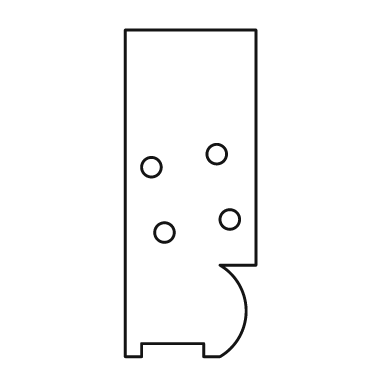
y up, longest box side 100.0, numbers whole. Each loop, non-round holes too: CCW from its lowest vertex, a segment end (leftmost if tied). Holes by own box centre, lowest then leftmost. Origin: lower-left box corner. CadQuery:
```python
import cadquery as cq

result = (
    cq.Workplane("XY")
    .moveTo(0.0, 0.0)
    .lineTo(5.0, 0.0)
    .lineTo(5.0, 4.0)
    .lineTo(24.0, 4.0)
    .lineTo(24.0, 0.0)
    .lineTo(29.0, 0.0)
    .threePointArc((37.0, 14.0), (29.0, 28.0))
    .lineTo(40.0, 28.0)
    .lineTo(40.0, 100.0)
    .lineTo(0.0, 100.0)
    .close()
    .moveTo(12.0, 38.0)
    .circle(3.0)
    .moveTo(32.0, 42.0)
    .circle(3.0)
    .moveTo(8.0, 58.0)
    .circle(3.0)
    .moveTo(28.0, 62.0)
    .circle(3.0)
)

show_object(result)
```